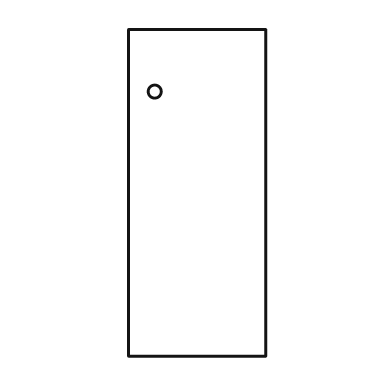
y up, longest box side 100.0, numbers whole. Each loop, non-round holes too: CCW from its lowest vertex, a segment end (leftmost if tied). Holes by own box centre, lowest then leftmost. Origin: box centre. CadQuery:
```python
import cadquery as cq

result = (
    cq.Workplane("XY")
    .moveTo(-21.0, -50.0)
    .lineTo(21.0, -50.0)
    .lineTo(21.0, 50.0)
    .lineTo(-21.0, 50.0)
    .close()
    .moveTo(-13.0, 31.0)
    .circle(2.0)
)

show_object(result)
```